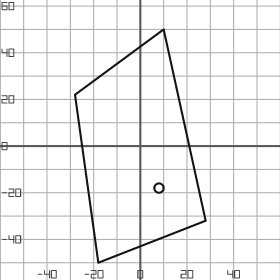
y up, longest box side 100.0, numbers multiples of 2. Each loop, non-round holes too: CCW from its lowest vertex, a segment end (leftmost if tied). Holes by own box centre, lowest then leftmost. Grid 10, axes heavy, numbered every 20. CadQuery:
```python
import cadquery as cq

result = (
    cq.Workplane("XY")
    .moveTo(-18.0, -50.0)
    .lineTo(28.0, -32.0)
    .lineTo(10.0, 50.0)
    .lineTo(-28.0, 22.0)
    .close()
    .moveTo(8.0, -18.0)
    .circle(2.0)
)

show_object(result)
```